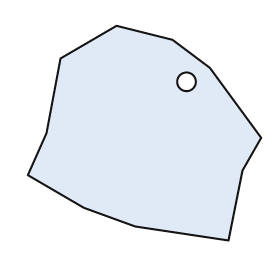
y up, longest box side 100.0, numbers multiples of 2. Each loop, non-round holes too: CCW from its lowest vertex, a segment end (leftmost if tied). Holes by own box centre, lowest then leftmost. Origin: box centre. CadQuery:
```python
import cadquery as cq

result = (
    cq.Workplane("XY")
    .moveTo(36.0, -46.0)
    .lineTo(42.0, -16.0)
    .lineTo(50.0, -2.0)
    .lineTo(28.0, 28.0)
    .lineTo(12.0, 40.0)
    .lineTo(-12.0, 46.0)
    .lineTo(-36.0, 32.0)
    .lineTo(-42.0, 0.0)
    .lineTo(-50.0, -18.0)
    .lineTo(-26.0, -32.0)
    .lineTo(-4.0, -40.0)
    .close()
    .moveTo(18.0, 22.0)
    .circle(4.0)
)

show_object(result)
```